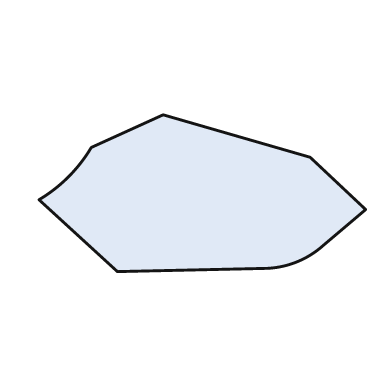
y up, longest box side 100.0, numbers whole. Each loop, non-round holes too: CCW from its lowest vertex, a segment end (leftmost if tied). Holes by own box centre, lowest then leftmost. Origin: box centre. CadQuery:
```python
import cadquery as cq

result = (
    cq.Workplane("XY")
    .moveTo(-26.0, -24.0)
    .lineTo(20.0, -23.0)
    .threePointArc((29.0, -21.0), (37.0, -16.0))
    .lineTo(50.0, -5.0)
    .lineTo(33.0, 11.0)
    .lineTo(-12.0, 24.0)
    .lineTo(-34.0, 14.0)
    .threePointArc((-41.0, 5.0), (-50.0, -2.0))
    .close()
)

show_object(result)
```